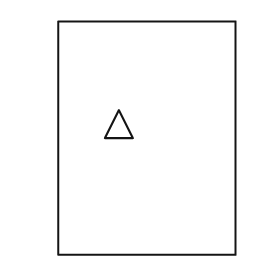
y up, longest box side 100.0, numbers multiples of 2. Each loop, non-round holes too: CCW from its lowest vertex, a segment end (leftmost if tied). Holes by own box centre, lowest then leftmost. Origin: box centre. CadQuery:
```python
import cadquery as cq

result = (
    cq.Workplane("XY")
    .moveTo(-38.0, -50.0)
    .lineTo(38.0, -50.0)
    .lineTo(38.0, 50.0)
    .lineTo(-38.0, 50.0)
    .close()
    .moveTo(-18.0, 0.0)
    .lineTo(-6.0, 0.0)
    .lineTo(-12.0, 12.0)
    .close()
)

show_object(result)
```